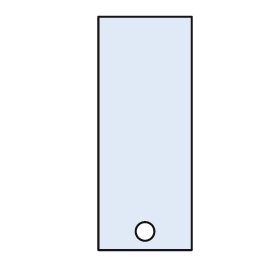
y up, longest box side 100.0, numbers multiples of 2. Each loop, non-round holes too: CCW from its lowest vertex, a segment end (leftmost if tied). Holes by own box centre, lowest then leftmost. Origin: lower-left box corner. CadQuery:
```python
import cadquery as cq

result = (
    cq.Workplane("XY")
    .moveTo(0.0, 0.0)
    .lineTo(40.0, 0.0)
    .lineTo(40.0, 100.0)
    .lineTo(0.0, 100.0)
    .close()
    .moveTo(20.0, 8.0)
    .circle(4.0)
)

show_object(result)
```